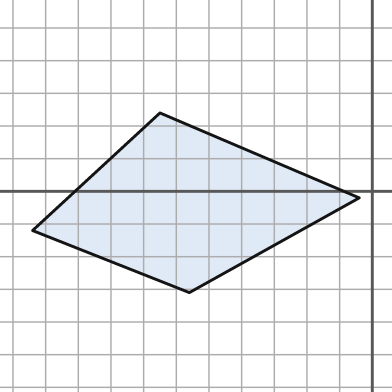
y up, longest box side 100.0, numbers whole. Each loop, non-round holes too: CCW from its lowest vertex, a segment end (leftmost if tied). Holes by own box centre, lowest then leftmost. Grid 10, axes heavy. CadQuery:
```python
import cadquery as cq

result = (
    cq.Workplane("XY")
    .moveTo(-56.0, -31.0)
    .lineTo(-4.0, -2.0)
    .lineTo(-65.0, 24.0)
    .lineTo(-104.0, -12.0)
    .close()
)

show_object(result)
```